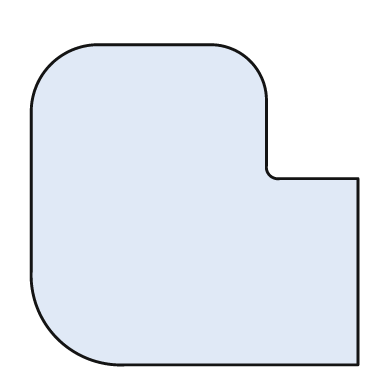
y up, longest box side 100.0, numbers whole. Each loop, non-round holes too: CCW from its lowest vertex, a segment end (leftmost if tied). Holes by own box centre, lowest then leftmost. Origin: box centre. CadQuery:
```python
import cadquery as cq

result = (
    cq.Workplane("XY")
    .moveTo(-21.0, -49.0)
    .lineTo(50.0, -49.0)
    .lineTo(50.0, 8.0)
    .lineTo(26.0, 8.0)
    .threePointArc((23.0, 9.0), (22.0, 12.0))
    .lineTo(22.0, 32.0)
    .threePointArc((17.0, 44.0), (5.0, 49.0))
    .lineTo(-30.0, 49.0)
    .threePointArc((-44.0, 43.0), (-50.0, 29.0))
    .lineTo(-50.0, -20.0)
    .threePointArc((-42.0, -41.0), (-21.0, -49.0))
    .close()
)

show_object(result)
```